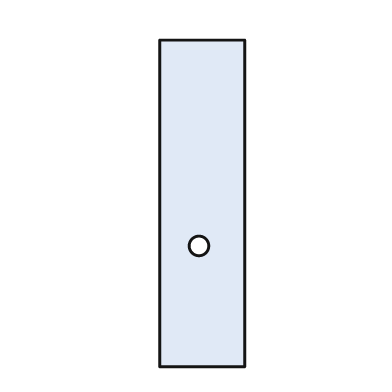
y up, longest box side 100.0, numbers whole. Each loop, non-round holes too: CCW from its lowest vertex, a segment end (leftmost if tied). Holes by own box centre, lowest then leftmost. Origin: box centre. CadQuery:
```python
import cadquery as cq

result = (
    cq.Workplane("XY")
    .moveTo(-13.0, -50.0)
    .lineTo(13.0, -50.0)
    .lineTo(13.0, 50.0)
    .lineTo(-13.0, 50.0)
    .close()
    .moveTo(-1.0, -13.0)
    .circle(3.0)
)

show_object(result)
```